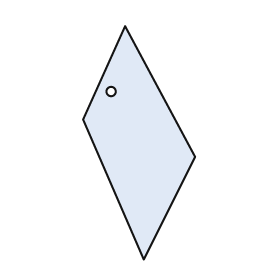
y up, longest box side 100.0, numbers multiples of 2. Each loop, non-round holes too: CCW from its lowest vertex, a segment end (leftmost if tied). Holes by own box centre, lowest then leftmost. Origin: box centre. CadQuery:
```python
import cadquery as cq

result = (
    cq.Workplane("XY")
    .moveTo(2.0, -50.0)
    .lineTo(24.0, -6.0)
    .lineTo(-6.0, 50.0)
    .lineTo(-24.0, 10.0)
    .close()
    .moveTo(-12.0, 22.0)
    .circle(2.0)
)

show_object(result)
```